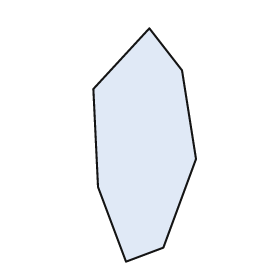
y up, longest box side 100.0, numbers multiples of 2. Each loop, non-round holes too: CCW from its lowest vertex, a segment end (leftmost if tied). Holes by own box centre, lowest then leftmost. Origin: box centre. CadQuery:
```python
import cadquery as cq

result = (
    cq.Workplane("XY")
    .moveTo(-8.0, -50.0)
    .lineTo(8.0, -44.0)
    .lineTo(22.0, -6.0)
    .lineTo(16.0, 32.0)
    .lineTo(2.0, 50.0)
    .lineTo(-22.0, 24.0)
    .lineTo(-20.0, -18.0)
    .close()
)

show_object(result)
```